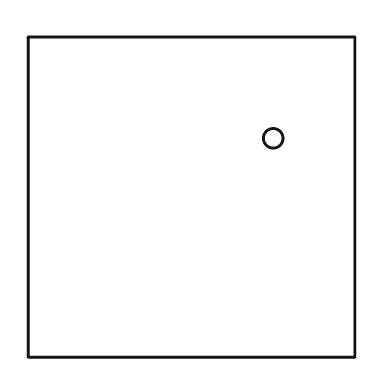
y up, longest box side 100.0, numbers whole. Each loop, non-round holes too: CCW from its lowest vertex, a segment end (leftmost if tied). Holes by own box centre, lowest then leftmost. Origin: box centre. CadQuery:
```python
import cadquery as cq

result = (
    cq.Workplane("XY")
    .moveTo(-50.0, -49.0)
    .lineTo(50.0, -49.0)
    .lineTo(50.0, 49.0)
    .lineTo(-50.0, 49.0)
    .close()
    .moveTo(25.0, 18.0)
    .circle(3.0)
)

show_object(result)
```